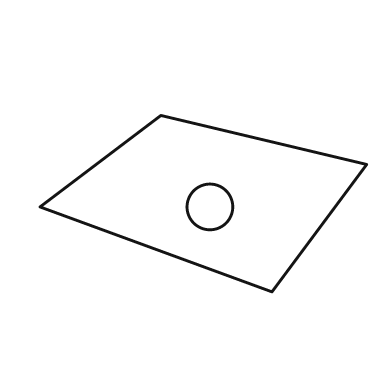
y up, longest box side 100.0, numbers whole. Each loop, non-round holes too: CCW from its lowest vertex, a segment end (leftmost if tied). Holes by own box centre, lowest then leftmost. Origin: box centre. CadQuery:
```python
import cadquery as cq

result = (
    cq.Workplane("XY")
    .moveTo(21.0, -27.0)
    .lineTo(50.0, 12.0)
    .lineTo(-13.0, 27.0)
    .lineTo(-50.0, -1.0)
    .close()
    .moveTo(2.0, -1.0)
    .circle(7.0)
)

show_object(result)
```